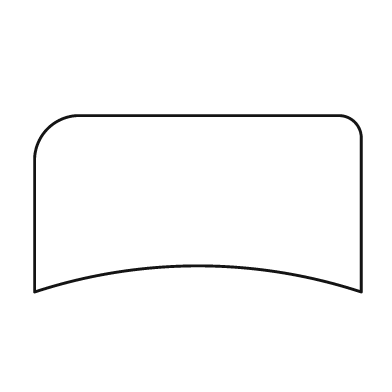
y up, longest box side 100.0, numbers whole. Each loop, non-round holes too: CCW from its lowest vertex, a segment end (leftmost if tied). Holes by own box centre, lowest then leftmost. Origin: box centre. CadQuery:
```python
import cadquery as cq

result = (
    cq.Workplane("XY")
    .moveTo(-50.0, -27.0)
    .threePointArc((0.0, -19.0), (50.0, -27.0))
    .lineTo(50.0, 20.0)
    .threePointArc((48.0, 25.0), (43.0, 27.0))
    .lineTo(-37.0, 27.0)
    .threePointArc((-46.0, 23.0), (-50.0, 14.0))
    .close()
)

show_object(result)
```